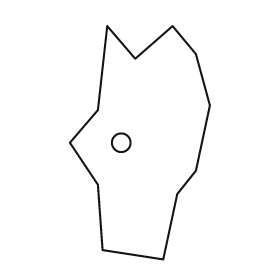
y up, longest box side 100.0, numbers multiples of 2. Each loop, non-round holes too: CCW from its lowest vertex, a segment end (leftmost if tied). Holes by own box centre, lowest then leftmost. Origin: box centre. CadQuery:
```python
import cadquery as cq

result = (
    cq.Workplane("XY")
    .moveTo(10.0, -50.0)
    .lineTo(16.0, -22.0)
    .lineTo(24.0, -12.0)
    .lineTo(30.0, 16.0)
    .lineTo(24.0, 38.0)
    .lineTo(14.0, 50.0)
    .lineTo(-2.0, 36.0)
    .lineTo(-14.0, 50.0)
    .lineTo(-18.0, 14.0)
    .lineTo(-30.0, 0.0)
    .lineTo(-18.0, -18.0)
    .lineTo(-16.0, -46.0)
    .close()
    .moveTo(-8.0, 0.0)
    .circle(4.0)
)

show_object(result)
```